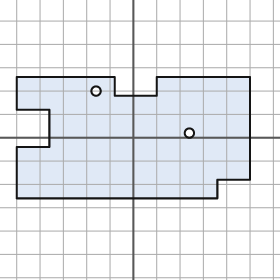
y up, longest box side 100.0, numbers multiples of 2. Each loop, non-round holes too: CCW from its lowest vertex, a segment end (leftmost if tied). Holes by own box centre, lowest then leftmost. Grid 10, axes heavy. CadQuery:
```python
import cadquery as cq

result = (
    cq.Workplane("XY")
    .moveTo(-50.0, -26.0)
    .lineTo(36.0, -26.0)
    .lineTo(36.0, -18.0)
    .lineTo(50.0, -18.0)
    .lineTo(50.0, 26.0)
    .lineTo(10.0, 26.0)
    .lineTo(10.0, 18.0)
    .lineTo(-8.0, 18.0)
    .lineTo(-8.0, 26.0)
    .lineTo(-50.0, 26.0)
    .lineTo(-50.0, 12.0)
    .lineTo(-36.0, 12.0)
    .lineTo(-36.0, -4.0)
    .lineTo(-50.0, -4.0)
    .close()
    .moveTo(24.0, 2.0)
    .circle(2.0)
    .moveTo(-16.0, 20.0)
    .circle(2.0)
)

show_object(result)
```